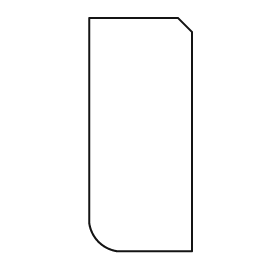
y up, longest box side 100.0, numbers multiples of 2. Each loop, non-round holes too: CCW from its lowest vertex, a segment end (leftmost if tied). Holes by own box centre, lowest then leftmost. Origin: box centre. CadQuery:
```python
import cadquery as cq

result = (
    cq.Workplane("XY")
    .moveTo(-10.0, -50.0)
    .lineTo(22.0, -50.0)
    .lineTo(22.0, 44.0)
    .lineTo(16.0, 50.0)
    .lineTo(-22.0, 50.0)
    .lineTo(-22.0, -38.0)
    .threePointArc((-18.0, -46.0), (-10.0, -50.0))
    .close()
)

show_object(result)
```